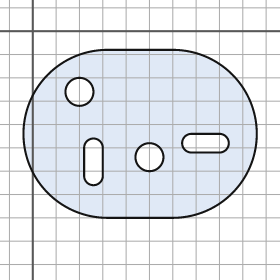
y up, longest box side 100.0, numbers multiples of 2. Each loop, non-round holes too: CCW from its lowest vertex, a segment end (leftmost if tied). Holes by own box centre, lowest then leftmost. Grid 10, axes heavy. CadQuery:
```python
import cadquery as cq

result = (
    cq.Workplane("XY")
    .moveTo(32.0, -80.0)
    .lineTo(60.0, -80.0)
    .threePointArc((96.0, -44.0), (60.0, -8.0))
    .lineTo(32.0, -8.0)
    .threePointArc((-4.0, -44.0), (32.0, -80.0))
    .close()
    .moveTo(22.0, -62.0)
    .threePointArc((26.0, -66.0), (30.0, -62.0))
    .lineTo(30.0, -50.0)
    .threePointArc((26.0, -46.0), (22.0, -50.0))
    .close()
    .moveTo(50.0, -54.0)
    .circle(6.0)
    .moveTo(68.0, -52.0)
    .lineTo(80.0, -52.0)
    .threePointArc((84.0, -48.0), (80.0, -44.0))
    .lineTo(68.0, -44.0)
    .threePointArc((64.0, -48.0), (68.0, -52.0))
    .close()
    .moveTo(20.0, -26.0)
    .circle(6.0)
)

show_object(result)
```